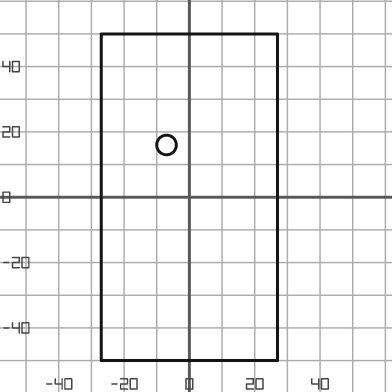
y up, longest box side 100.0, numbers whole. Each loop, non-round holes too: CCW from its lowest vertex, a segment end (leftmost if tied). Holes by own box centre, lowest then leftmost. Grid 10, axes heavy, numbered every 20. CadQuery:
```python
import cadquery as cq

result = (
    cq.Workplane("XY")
    .moveTo(-27.0, -50.0)
    .lineTo(27.0, -50.0)
    .lineTo(27.0, 50.0)
    .lineTo(-27.0, 50.0)
    .close()
    .moveTo(-7.0, 16.0)
    .circle(3.0)
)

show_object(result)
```